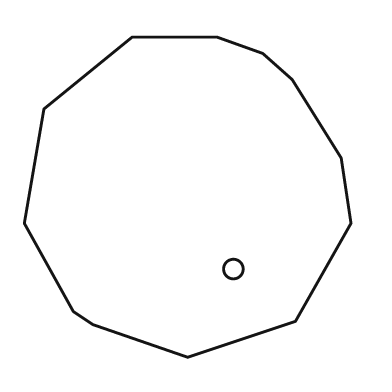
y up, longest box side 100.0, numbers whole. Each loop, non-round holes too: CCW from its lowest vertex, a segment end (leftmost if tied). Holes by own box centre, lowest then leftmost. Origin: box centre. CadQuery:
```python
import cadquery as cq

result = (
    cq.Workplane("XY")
    .moveTo(0.0, -49.0)
    .lineTo(33.0, -38.0)
    .lineTo(50.0, -8.0)
    .lineTo(47.0, 12.0)
    .lineTo(32.0, 36.0)
    .lineTo(23.0, 44.0)
    .lineTo(9.0, 49.0)
    .lineTo(-17.0, 49.0)
    .lineTo(-44.0, 27.0)
    .lineTo(-50.0, -8.0)
    .lineTo(-35.0, -35.0)
    .lineTo(-29.0, -39.0)
    .close()
    .moveTo(14.0, -22.0)
    .circle(3.0)
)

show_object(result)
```